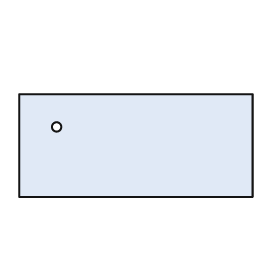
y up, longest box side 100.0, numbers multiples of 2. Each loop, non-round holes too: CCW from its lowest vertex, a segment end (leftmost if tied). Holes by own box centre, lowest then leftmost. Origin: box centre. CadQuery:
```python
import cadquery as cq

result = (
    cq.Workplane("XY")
    .moveTo(-50.0, -22.0)
    .lineTo(50.0, -22.0)
    .lineTo(50.0, 22.0)
    .lineTo(-50.0, 22.0)
    .close()
    .moveTo(-34.0, 8.0)
    .circle(2.0)
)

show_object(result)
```